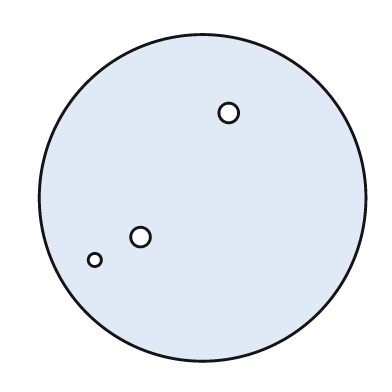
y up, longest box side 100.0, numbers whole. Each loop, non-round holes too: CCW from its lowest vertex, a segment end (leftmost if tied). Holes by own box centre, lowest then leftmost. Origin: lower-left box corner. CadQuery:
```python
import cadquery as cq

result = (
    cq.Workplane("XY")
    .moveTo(50.0, 50.0)
    .circle(50.0)
    .moveTo(17.0, 31.0)
    .circle(2.0)
    .moveTo(31.0, 38.0)
    .circle(3.0)
    .moveTo(58.0, 76.0)
    .circle(3.0)
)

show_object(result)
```